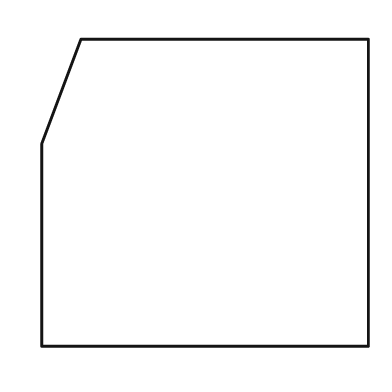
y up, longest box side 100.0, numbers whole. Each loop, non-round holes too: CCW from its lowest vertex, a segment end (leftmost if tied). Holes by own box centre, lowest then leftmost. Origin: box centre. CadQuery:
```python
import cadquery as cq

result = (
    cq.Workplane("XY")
    .moveTo(-50.0, -47.0)
    .lineTo(50.0, -47.0)
    .lineTo(50.0, 47.0)
    .lineTo(-38.0, 47.0)
    .lineTo(-50.0, 15.0)
    .close()
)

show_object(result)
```